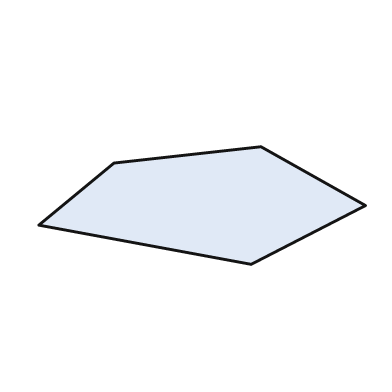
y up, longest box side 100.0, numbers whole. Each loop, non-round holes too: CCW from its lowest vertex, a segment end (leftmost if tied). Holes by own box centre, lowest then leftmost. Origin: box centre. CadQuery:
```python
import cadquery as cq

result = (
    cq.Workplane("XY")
    .moveTo(15.0, -18.0)
    .lineTo(50.0, 0.0)
    .lineTo(18.0, 18.0)
    .lineTo(-27.0, 13.0)
    .lineTo(-50.0, -6.0)
    .close()
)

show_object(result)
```